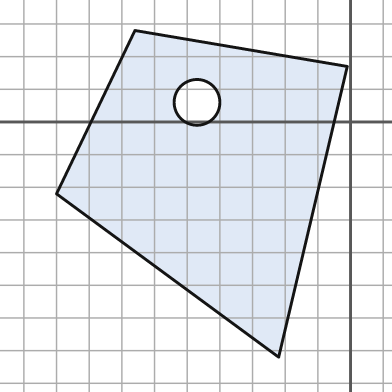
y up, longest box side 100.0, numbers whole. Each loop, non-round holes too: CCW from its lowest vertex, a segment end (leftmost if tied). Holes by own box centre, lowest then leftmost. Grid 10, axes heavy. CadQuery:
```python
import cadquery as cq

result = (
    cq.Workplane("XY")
    .moveTo(-22.0, -72.0)
    .lineTo(-1.0, 17.0)
    .lineTo(-66.0, 28.0)
    .lineTo(-90.0, -22.0)
    .close()
    .moveTo(-47.0, 6.0)
    .circle(7.0)
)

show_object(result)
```